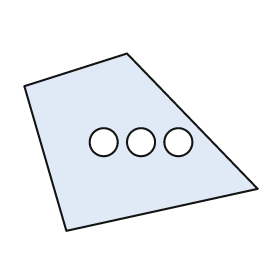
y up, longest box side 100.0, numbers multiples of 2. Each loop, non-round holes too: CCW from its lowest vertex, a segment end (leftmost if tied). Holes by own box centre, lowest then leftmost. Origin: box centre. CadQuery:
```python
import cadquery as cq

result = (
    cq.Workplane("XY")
    .moveTo(-32.0, -38.0)
    .lineTo(50.0, -20.0)
    .lineTo(-6.0, 38.0)
    .lineTo(-50.0, 24.0)
    .close()
    .moveTo(-16.0, 0.0)
    .circle(6.0)
    .moveTo(0.0, 0.0)
    .circle(6.0)
    .moveTo(16.0, 0.0)
    .circle(6.0)
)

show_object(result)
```